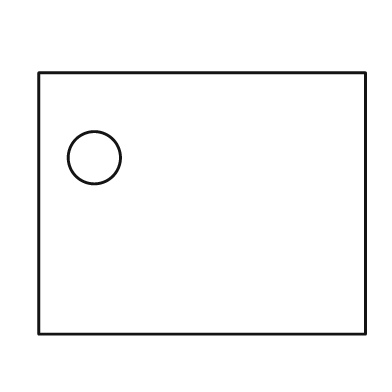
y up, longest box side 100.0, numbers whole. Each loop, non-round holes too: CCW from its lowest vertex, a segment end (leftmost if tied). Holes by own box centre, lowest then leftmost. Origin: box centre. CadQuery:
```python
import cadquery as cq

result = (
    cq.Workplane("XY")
    .moveTo(-50.0, -40.0)
    .lineTo(50.0, -40.0)
    .lineTo(50.0, 40.0)
    .lineTo(-50.0, 40.0)
    .close()
    .moveTo(-33.0, 14.0)
    .circle(8.0)
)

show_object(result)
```